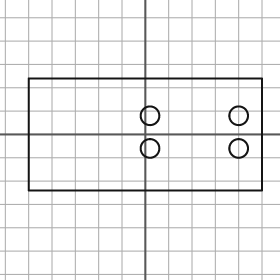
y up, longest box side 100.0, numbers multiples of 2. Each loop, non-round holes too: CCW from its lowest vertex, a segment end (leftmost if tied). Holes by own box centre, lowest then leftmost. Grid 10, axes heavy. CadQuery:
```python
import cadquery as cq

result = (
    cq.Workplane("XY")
    .moveTo(-50.0, -24.0)
    .lineTo(50.0, -24.0)
    .lineTo(50.0, 24.0)
    .lineTo(-50.0, 24.0)
    .close()
    .moveTo(2.0, -6.0)
    .circle(4.0)
    .moveTo(40.0, -6.0)
    .circle(4.0)
    .moveTo(2.0, 8.0)
    .circle(4.0)
    .moveTo(40.0, 8.0)
    .circle(4.0)
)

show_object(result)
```